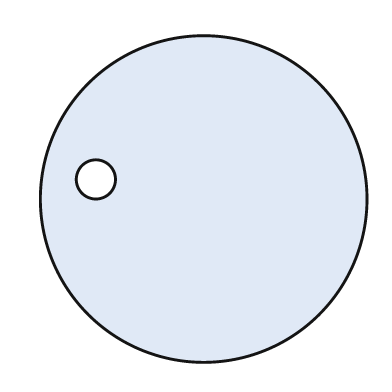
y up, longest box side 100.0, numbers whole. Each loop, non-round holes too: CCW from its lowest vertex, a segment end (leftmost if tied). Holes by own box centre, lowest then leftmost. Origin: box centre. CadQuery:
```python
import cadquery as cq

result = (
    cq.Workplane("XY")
    .moveTo(0.0, 0.0)
    .circle(50.0)
    .moveTo(-33.0, 6.0)
    .circle(6.0)
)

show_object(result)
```